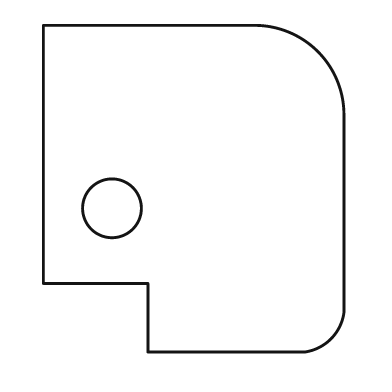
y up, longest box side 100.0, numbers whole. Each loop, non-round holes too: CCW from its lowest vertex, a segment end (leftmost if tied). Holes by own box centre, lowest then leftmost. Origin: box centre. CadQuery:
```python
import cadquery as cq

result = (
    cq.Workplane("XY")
    .moveTo(-14.0, -50.0)
    .lineTo(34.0, -50.0)
    .threePointArc((42.0, -46.0), (46.0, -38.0))
    .lineTo(46.0, 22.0)
    .threePointArc((38.0, 42.0), (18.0, 50.0))
    .lineTo(-46.0, 50.0)
    .lineTo(-46.0, -29.0)
    .lineTo(-14.0, -29.0)
    .close()
    .moveTo(-25.0, -6.0)
    .circle(9.0)
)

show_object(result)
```